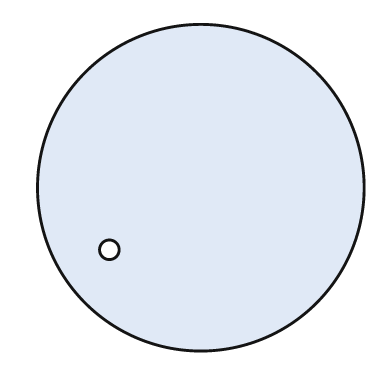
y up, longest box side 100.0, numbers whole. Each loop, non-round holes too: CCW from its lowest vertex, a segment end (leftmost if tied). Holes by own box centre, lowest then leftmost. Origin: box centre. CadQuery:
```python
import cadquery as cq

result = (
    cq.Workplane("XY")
    .moveTo(0.0, 0.0)
    .circle(50.0)
    .moveTo(-28.0, -19.0)
    .circle(3.0)
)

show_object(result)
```